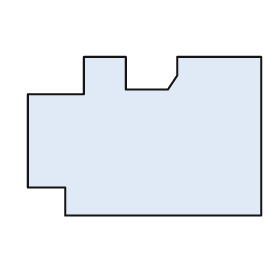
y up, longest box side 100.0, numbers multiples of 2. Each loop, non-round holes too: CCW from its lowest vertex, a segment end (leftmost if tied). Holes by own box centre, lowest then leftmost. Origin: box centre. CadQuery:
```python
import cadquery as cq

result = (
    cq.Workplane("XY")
    .moveTo(-34.0, -34.0)
    .lineTo(50.0, -34.0)
    .lineTo(50.0, 34.0)
    .lineTo(14.0, 34.0)
    .lineTo(14.0, 26.0)
    .lineTo(10.0, 20.0)
    .lineTo(-8.0, 20.0)
    .lineTo(-8.0, 34.0)
    .lineTo(-26.0, 34.0)
    .lineTo(-26.0, 18.0)
    .lineTo(-50.0, 18.0)
    .lineTo(-50.0, -22.0)
    .lineTo(-34.0, -22.0)
    .close()
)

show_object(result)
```